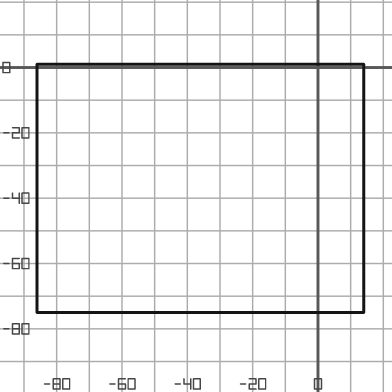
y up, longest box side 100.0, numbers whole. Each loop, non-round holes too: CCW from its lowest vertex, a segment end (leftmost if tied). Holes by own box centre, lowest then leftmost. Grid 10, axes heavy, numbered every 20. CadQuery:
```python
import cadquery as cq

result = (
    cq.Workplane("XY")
    .moveTo(-86.0, -75.0)
    .lineTo(14.0, -75.0)
    .lineTo(14.0, 1.0)
    .lineTo(-86.0, 1.0)
    .close()
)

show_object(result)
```